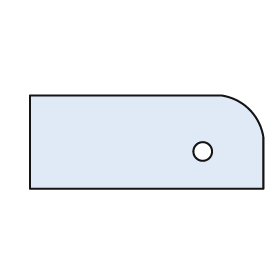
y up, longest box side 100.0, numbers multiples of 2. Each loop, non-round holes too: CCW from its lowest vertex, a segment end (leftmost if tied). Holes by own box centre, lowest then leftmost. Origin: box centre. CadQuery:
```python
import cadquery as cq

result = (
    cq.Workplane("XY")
    .moveTo(-50.0, -20.0)
    .lineTo(50.0, -20.0)
    .lineTo(50.0, 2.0)
    .threePointArc((44.0, 14.0), (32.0, 20.0))
    .lineTo(-50.0, 20.0)
    .close()
    .moveTo(24.0, -4.0)
    .circle(4.0)
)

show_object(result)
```